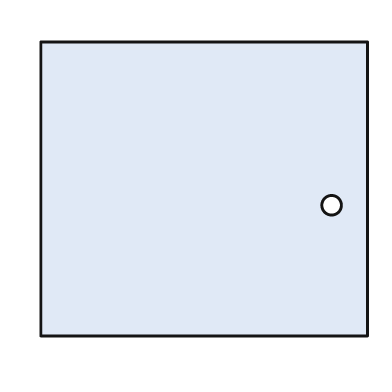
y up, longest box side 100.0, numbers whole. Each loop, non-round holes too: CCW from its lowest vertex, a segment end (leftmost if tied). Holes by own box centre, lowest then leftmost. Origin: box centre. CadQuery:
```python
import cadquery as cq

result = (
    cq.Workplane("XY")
    .moveTo(-50.0, -45.0)
    .lineTo(50.0, -45.0)
    .lineTo(50.0, 45.0)
    .lineTo(-50.0, 45.0)
    .close()
    .moveTo(39.0, -5.0)
    .circle(3.0)
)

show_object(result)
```